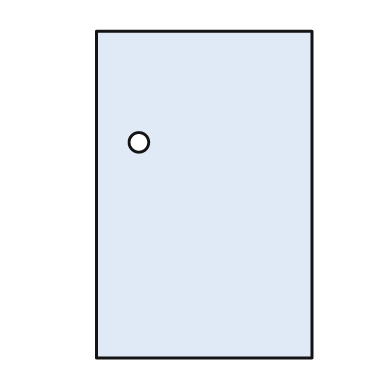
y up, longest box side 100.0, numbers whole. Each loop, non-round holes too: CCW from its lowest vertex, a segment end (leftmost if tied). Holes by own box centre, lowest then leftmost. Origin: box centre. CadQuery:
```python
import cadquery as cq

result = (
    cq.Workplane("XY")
    .moveTo(-33.0, -50.0)
    .lineTo(33.0, -50.0)
    .lineTo(33.0, 50.0)
    .lineTo(-33.0, 50.0)
    .close()
    .moveTo(-20.0, 16.0)
    .circle(3.0)
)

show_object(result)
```